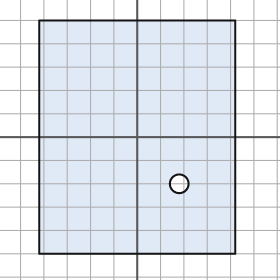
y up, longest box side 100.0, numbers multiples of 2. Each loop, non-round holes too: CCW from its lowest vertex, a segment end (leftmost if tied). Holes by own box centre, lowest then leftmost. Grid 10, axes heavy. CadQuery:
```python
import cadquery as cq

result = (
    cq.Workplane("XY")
    .moveTo(-42.0, -50.0)
    .lineTo(42.0, -50.0)
    .lineTo(42.0, 50.0)
    .lineTo(-42.0, 50.0)
    .close()
    .moveTo(18.0, -20.0)
    .circle(4.0)
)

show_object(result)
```